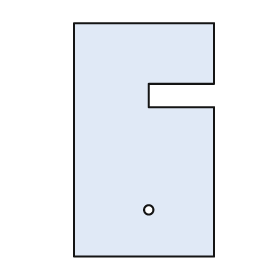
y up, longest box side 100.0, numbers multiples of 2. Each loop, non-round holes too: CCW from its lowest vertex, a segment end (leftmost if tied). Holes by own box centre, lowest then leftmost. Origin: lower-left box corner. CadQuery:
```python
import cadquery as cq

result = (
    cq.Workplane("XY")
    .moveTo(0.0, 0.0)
    .lineTo(60.0, 0.0)
    .lineTo(60.0, 64.0)
    .lineTo(32.0, 64.0)
    .lineTo(32.0, 74.0)
    .lineTo(60.0, 74.0)
    .lineTo(60.0, 100.0)
    .lineTo(0.0, 100.0)
    .close()
    .moveTo(32.0, 20.0)
    .circle(2.0)
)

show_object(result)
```